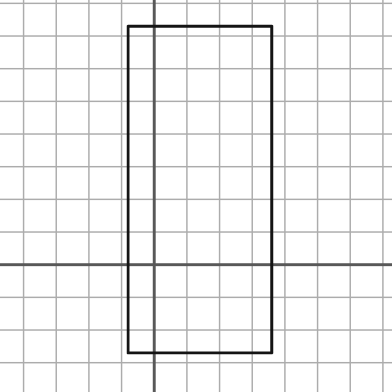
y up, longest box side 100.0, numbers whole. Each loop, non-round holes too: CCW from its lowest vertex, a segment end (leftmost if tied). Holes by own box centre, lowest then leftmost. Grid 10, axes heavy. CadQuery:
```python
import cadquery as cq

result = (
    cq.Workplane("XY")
    .moveTo(-8.0, -27.0)
    .lineTo(36.0, -27.0)
    .lineTo(36.0, 73.0)
    .lineTo(-8.0, 73.0)
    .close()
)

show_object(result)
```